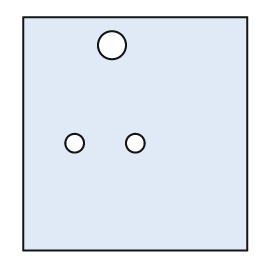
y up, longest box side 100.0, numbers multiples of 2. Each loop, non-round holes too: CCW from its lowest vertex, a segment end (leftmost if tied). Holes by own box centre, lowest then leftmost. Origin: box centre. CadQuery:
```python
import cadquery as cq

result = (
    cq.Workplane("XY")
    .moveTo(-48.0, -50.0)
    .lineTo(48.0, -50.0)
    .lineTo(48.0, 50.0)
    .lineTo(-48.0, 50.0)
    .close()
    .moveTo(-26.0, -4.0)
    .circle(4.0)
    .moveTo(0.0, -4.0)
    .circle(4.0)
    .moveTo(-10.0, 38.0)
    .circle(6.0)
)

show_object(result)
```